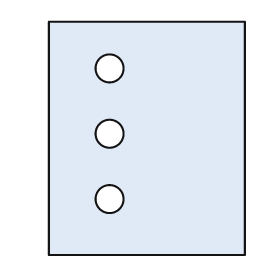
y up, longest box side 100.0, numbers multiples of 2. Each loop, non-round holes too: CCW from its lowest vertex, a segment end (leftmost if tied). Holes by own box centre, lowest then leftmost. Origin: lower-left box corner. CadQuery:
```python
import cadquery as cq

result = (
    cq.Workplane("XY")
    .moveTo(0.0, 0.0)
    .lineTo(84.0, 0.0)
    .lineTo(84.0, 100.0)
    .lineTo(0.0, 100.0)
    .close()
    .moveTo(26.0, 24.0)
    .circle(6.0)
    .moveTo(26.0, 52.0)
    .circle(6.0)
    .moveTo(26.0, 80.0)
    .circle(6.0)
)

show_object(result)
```